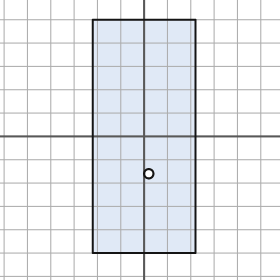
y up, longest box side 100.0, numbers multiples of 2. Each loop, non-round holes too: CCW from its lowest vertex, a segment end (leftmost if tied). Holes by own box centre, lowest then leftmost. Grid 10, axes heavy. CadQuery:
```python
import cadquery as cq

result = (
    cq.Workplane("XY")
    .moveTo(-22.0, -50.0)
    .lineTo(22.0, -50.0)
    .lineTo(22.0, 50.0)
    .lineTo(-22.0, 50.0)
    .close()
    .moveTo(2.0, -16.0)
    .circle(2.0)
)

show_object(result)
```